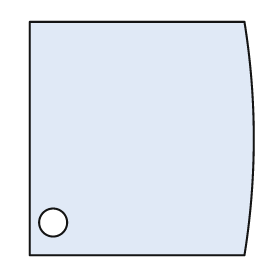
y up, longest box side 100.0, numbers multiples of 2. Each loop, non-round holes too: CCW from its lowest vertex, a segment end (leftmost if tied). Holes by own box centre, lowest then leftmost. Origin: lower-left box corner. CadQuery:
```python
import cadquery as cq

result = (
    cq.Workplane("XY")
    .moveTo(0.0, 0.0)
    .lineTo(92.0, 0.0)
    .threePointArc((96.0, 50.0), (92.0, 100.0))
    .lineTo(0.0, 100.0)
    .close()
    .moveTo(10.0, 14.0)
    .circle(6.0)
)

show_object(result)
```